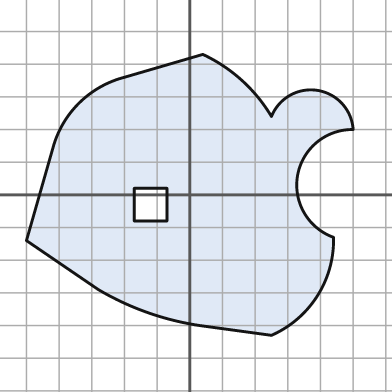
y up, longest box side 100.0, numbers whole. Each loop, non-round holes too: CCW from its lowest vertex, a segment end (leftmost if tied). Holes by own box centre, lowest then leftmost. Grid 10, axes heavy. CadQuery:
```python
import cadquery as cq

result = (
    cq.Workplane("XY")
    .moveTo(25.0, -43.0)
    .threePointArc((39.0, -31.0), (44.0, -13.0))
    .threePointArc((33.0, 6.0), (50.0, 20.0))
    .threePointArc((39.0, 32.0), (25.0, 24.0))
    .threePointArc((16.0, 35.0), (4.0, 43.0))
    .lineTo(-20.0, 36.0)
    .threePointArc((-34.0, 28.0), (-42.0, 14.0))
    .lineTo(-50.0, -14.0)
    .lineTo(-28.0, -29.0)
    .threePointArc((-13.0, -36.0), (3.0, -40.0))
    .close()
    .moveTo(-17.0, -8.0)
    .lineTo(-7.0, -8.0)
    .lineTo(-7.0, 2.0)
    .lineTo(-17.0, 2.0)
    .close()
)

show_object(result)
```